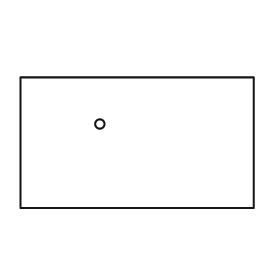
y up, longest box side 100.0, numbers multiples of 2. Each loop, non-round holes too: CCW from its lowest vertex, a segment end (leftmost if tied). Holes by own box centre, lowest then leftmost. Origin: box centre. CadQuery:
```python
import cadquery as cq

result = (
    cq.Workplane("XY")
    .moveTo(-50.0, -28.0)
    .lineTo(50.0, -28.0)
    .lineTo(50.0, 28.0)
    .lineTo(-50.0, 28.0)
    .close()
    .moveTo(-16.0, 8.0)
    .circle(2.0)
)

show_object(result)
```